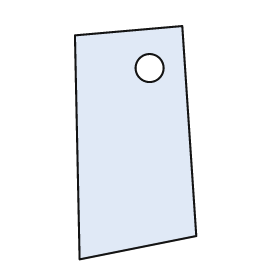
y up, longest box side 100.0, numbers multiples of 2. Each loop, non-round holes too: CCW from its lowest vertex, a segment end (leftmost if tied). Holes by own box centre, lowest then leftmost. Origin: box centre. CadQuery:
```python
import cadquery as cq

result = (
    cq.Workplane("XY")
    .moveTo(-24.0, -50.0)
    .lineTo(26.0, -40.0)
    .lineTo(20.0, 50.0)
    .lineTo(-26.0, 46.0)
    .close()
    .moveTo(6.0, 32.0)
    .circle(6.0)
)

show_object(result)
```